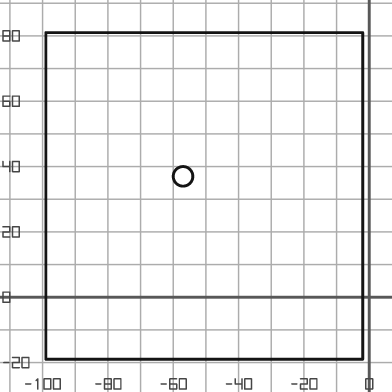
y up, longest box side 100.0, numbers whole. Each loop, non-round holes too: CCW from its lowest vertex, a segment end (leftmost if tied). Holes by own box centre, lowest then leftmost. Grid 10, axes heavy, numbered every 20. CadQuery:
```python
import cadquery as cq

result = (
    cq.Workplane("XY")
    .moveTo(-99.0, -19.0)
    .lineTo(-2.0, -19.0)
    .lineTo(-2.0, 81.0)
    .lineTo(-99.0, 81.0)
    .close()
    .moveTo(-57.0, 37.0)
    .circle(3.0)
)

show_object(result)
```